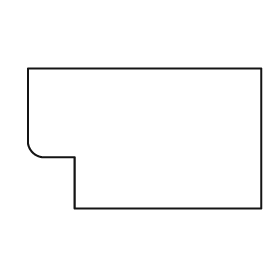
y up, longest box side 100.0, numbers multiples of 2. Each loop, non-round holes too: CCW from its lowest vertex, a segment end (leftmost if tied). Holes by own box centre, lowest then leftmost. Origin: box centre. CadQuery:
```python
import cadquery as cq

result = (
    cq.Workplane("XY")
    .moveTo(-30.0, -30.0)
    .lineTo(50.0, -30.0)
    .lineTo(50.0, 30.0)
    .lineTo(-50.0, 30.0)
    .lineTo(-50.0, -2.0)
    .threePointArc((-48.0, -6.0), (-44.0, -8.0))
    .lineTo(-30.0, -8.0)
    .close()
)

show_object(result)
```